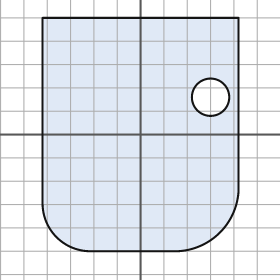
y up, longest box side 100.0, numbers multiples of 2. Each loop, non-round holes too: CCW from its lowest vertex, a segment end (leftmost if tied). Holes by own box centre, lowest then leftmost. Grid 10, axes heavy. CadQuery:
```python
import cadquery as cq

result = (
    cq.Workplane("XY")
    .moveTo(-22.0, -50.0)
    .lineTo(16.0, -50.0)
    .threePointArc((34.0, -42.0), (42.0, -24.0))
    .lineTo(42.0, 50.0)
    .lineTo(-42.0, 50.0)
    .lineTo(-42.0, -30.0)
    .threePointArc((-36.0, -44.0), (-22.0, -50.0))
    .close()
    .moveTo(30.0, 16.0)
    .circle(8.0)
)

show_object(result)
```